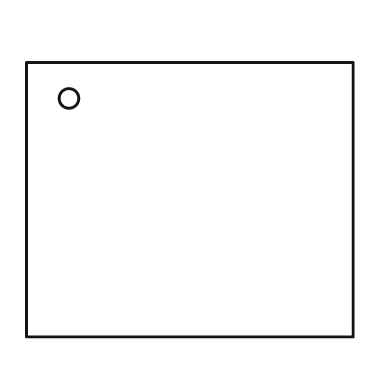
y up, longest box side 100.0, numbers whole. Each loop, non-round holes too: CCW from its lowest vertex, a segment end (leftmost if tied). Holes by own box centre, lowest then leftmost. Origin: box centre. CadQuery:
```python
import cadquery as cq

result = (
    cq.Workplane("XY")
    .moveTo(-50.0, -42.0)
    .lineTo(50.0, -42.0)
    .lineTo(50.0, 42.0)
    .lineTo(-50.0, 42.0)
    .close()
    .moveTo(-37.0, 31.0)
    .circle(3.0)
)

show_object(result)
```